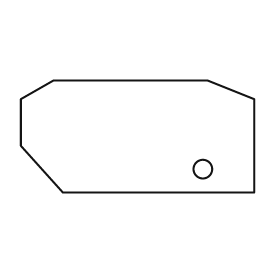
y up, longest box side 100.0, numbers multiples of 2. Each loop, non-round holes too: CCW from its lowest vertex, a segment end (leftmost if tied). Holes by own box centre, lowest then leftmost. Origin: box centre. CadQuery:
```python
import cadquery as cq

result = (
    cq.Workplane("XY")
    .moveTo(-32.0, -24.0)
    .lineTo(50.0, -24.0)
    .lineTo(50.0, 16.0)
    .lineTo(30.0, 24.0)
    .lineTo(-36.0, 24.0)
    .lineTo(-50.0, 16.0)
    .lineTo(-50.0, -4.0)
    .close()
    .moveTo(28.0, -14.0)
    .circle(4.0)
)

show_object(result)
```